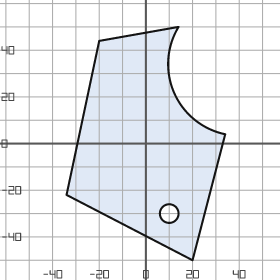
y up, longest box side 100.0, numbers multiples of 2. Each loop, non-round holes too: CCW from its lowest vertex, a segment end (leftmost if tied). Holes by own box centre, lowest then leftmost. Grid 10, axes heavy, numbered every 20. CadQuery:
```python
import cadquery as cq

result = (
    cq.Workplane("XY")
    .moveTo(20.0, -50.0)
    .lineTo(34.0, 4.0)
    .threePointArc((12.0, 22.0), (14.0, 50.0))
    .lineTo(-20.0, 44.0)
    .lineTo(-34.0, -22.0)
    .close()
    .moveTo(10.0, -30.0)
    .circle(4.0)
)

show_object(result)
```